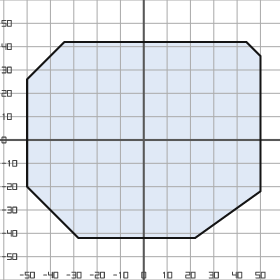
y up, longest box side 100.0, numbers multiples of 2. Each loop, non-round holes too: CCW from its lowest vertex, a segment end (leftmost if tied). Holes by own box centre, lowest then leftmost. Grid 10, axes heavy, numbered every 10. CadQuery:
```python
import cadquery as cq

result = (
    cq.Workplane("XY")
    .moveTo(-28.0, -42.0)
    .lineTo(22.0, -42.0)
    .lineTo(50.0, -22.0)
    .lineTo(50.0, 36.0)
    .lineTo(44.0, 42.0)
    .lineTo(-34.0, 42.0)
    .lineTo(-50.0, 26.0)
    .lineTo(-50.0, -20.0)
    .close()
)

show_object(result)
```